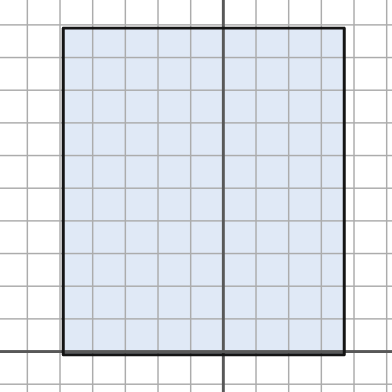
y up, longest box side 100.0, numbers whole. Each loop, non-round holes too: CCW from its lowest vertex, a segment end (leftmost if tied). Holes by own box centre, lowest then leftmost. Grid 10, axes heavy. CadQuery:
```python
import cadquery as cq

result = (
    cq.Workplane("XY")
    .moveTo(-49.0, -1.0)
    .lineTo(37.0, -1.0)
    .lineTo(37.0, 99.0)
    .lineTo(-49.0, 99.0)
    .close()
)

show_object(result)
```